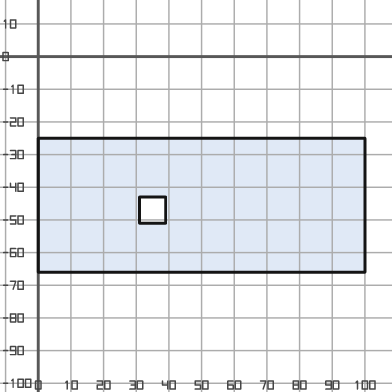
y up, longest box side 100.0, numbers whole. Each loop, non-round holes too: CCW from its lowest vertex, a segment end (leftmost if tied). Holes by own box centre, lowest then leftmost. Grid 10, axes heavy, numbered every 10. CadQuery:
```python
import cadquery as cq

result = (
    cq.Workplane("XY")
    .moveTo(0.0, -66.0)
    .lineTo(100.0, -66.0)
    .lineTo(100.0, -25.0)
    .lineTo(0.0, -25.0)
    .close()
    .moveTo(31.0, -51.0)
    .lineTo(39.0, -51.0)
    .lineTo(39.0, -43.0)
    .lineTo(31.0, -43.0)
    .close()
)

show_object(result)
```